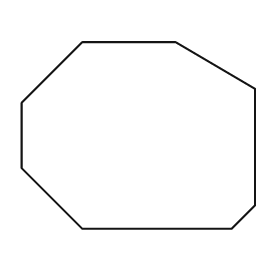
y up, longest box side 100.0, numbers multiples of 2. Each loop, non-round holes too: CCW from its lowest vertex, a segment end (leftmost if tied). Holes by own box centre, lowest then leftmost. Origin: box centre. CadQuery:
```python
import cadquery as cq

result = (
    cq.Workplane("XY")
    .moveTo(-24.0, -40.0)
    .lineTo(40.0, -40.0)
    .lineTo(50.0, -30.0)
    .lineTo(50.0, 20.0)
    .lineTo(16.0, 40.0)
    .lineTo(-24.0, 40.0)
    .lineTo(-50.0, 14.0)
    .lineTo(-50.0, -14.0)
    .close()
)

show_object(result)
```